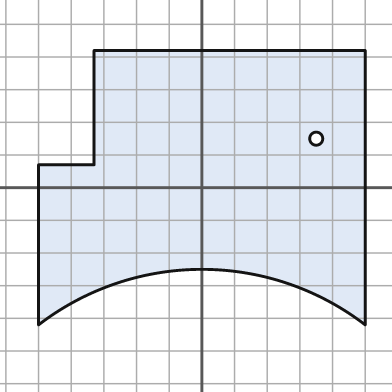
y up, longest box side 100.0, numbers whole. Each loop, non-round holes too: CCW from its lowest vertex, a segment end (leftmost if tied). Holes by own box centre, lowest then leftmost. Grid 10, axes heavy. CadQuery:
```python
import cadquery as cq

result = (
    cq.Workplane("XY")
    .moveTo(-50.0, -42.0)
    .threePointArc((0.0, -25.0), (50.0, -42.0))
    .lineTo(50.0, 42.0)
    .lineTo(-33.0, 42.0)
    .lineTo(-33.0, 7.0)
    .lineTo(-50.0, 7.0)
    .close()
    .moveTo(35.0, 15.0)
    .circle(2.0)
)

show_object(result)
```